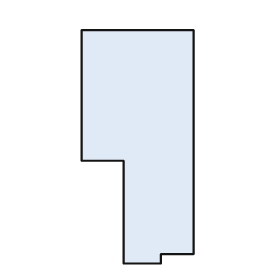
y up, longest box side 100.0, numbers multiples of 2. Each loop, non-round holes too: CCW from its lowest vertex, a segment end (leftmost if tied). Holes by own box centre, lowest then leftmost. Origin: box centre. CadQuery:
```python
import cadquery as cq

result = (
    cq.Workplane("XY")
    .moveTo(-6.0, -50.0)
    .lineTo(10.0, -50.0)
    .lineTo(10.0, -46.0)
    .lineTo(24.0, -46.0)
    .lineTo(24.0, 50.0)
    .lineTo(-24.0, 50.0)
    .lineTo(-24.0, -6.0)
    .lineTo(-6.0, -6.0)
    .close()
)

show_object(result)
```